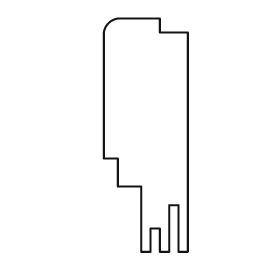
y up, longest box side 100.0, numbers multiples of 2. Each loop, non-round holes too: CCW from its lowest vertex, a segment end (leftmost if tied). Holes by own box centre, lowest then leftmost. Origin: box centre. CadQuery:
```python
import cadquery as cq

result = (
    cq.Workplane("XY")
    .moveTo(-2.0, -50.0)
    .lineTo(2.0, -50.0)
    .lineTo(2.0, -40.0)
    .lineTo(6.0, -40.0)
    .lineTo(6.0, -50.0)
    .lineTo(10.0, -50.0)
    .lineTo(10.0, -30.0)
    .lineTo(14.0, -30.0)
    .lineTo(14.0, -50.0)
    .lineTo(18.0, -50.0)
    .lineTo(18.0, 44.0)
    .lineTo(6.0, 44.0)
    .lineTo(6.0, 50.0)
    .lineTo(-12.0, 50.0)
    .threePointArc((-16.0, 48.0), (-18.0, 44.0))
    .lineTo(-18.0, -10.0)
    .lineTo(-12.0, -10.0)
    .lineTo(-12.0, -22.0)
    .lineTo(-2.0, -22.0)
    .close()
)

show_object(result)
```